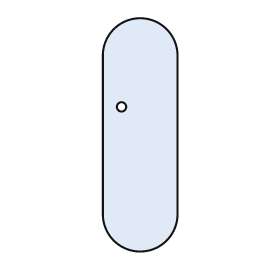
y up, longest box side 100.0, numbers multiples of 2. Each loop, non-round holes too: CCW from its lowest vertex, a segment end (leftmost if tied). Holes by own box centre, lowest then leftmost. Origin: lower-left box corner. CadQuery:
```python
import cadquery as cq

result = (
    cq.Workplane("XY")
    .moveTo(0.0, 16.0)
    .threePointArc((16.0, 0.0), (32.0, 16.0))
    .lineTo(32.0, 84.0)
    .threePointArc((16.0, 100.0), (0.0, 84.0))
    .close()
    .moveTo(8.0, 62.0)
    .circle(2.0)
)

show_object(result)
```